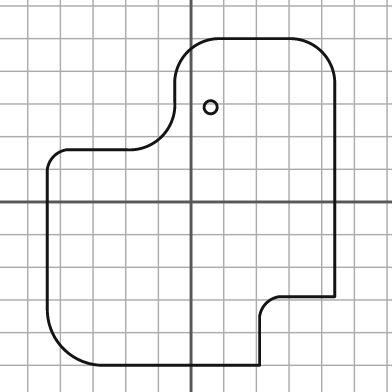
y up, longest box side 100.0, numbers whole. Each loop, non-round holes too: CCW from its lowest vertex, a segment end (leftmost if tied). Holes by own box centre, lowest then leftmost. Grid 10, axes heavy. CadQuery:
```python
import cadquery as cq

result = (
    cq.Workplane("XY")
    .moveTo(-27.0, -50.0)
    .lineTo(21.0, -50.0)
    .lineTo(21.0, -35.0)
    .threePointArc((23.0, -31.0), (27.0, -29.0))
    .lineTo(44.0, -29.0)
    .lineTo(44.0, 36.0)
    .threePointArc((40.0, 46.0), (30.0, 50.0))
    .lineTo(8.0, 50.0)
    .threePointArc((-1.0, 46.0), (-5.0, 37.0))
    .lineTo(-5.0, 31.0)
    .threePointArc((-9.0, 20.0), (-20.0, 16.0))
    .lineTo(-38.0, 16.0)
    .threePointArc((-42.0, 14.0), (-44.0, 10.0))
    .lineTo(-44.0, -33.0)
    .threePointArc((-39.0, -45.0), (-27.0, -50.0))
    .close()
    .moveTo(6.0, 29.0)
    .circle(2.0)
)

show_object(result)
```